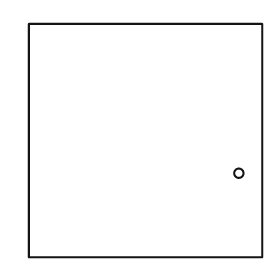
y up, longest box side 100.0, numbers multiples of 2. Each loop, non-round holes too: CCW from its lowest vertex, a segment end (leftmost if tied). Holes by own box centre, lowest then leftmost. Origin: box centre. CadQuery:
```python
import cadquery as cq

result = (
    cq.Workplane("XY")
    .moveTo(-50.0, -50.0)
    .lineTo(50.0, -50.0)
    .lineTo(50.0, 50.0)
    .lineTo(-50.0, 50.0)
    .close()
    .moveTo(40.0, -14.0)
    .circle(2.0)
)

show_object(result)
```